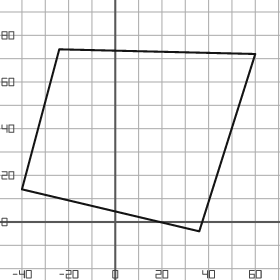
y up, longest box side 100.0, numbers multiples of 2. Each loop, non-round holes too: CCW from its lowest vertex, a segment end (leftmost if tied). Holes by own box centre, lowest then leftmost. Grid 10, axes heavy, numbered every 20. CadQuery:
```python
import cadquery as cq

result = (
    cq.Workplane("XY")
    .moveTo(36.0, -4.0)
    .lineTo(60.0, 72.0)
    .lineTo(-24.0, 74.0)
    .lineTo(-40.0, 14.0)
    .close()
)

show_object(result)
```